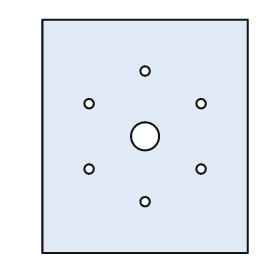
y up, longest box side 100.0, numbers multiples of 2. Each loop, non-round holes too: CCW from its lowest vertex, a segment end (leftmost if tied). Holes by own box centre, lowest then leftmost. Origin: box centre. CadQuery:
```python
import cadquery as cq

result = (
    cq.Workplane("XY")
    .moveTo(-44.0, -50.0)
    .lineTo(44.0, -50.0)
    .lineTo(44.0, 50.0)
    .lineTo(-44.0, 50.0)
    .close()
    .moveTo(0.0, -28.0)
    .circle(2.0)
    .moveTo(-24.0, -14.0)
    .circle(2.0)
    .moveTo(24.0, -14.0)
    .circle(2.0)
    .moveTo(0.0, 0.0)
    .circle(6.0)
    .moveTo(-24.0, 14.0)
    .circle(2.0)
    .moveTo(24.0, 14.0)
    .circle(2.0)
    .moveTo(0.0, 28.0)
    .circle(2.0)
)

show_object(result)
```